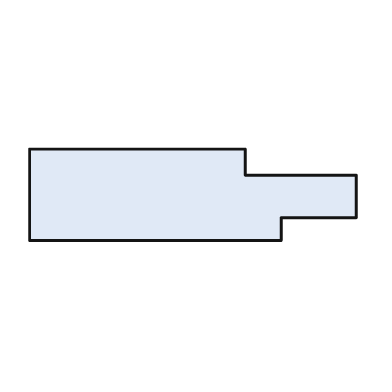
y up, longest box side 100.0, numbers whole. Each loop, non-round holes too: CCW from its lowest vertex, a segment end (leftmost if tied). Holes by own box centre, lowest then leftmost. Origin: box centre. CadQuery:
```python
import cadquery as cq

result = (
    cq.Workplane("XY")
    .moveTo(-50.0, -14.0)
    .lineTo(27.0, -14.0)
    .lineTo(27.0, -7.0)
    .lineTo(50.0, -7.0)
    .lineTo(50.0, 6.0)
    .lineTo(16.0, 6.0)
    .lineTo(16.0, 14.0)
    .lineTo(-50.0, 14.0)
    .close()
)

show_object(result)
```